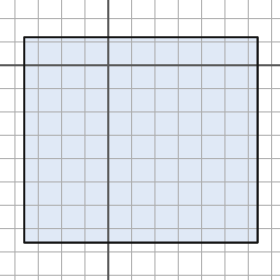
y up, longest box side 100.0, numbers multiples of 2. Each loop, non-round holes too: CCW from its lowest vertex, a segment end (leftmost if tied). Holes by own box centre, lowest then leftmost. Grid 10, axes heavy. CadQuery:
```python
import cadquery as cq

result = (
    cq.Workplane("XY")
    .moveTo(-36.0, -76.0)
    .lineTo(64.0, -76.0)
    .lineTo(64.0, 12.0)
    .lineTo(-36.0, 12.0)
    .close()
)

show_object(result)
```